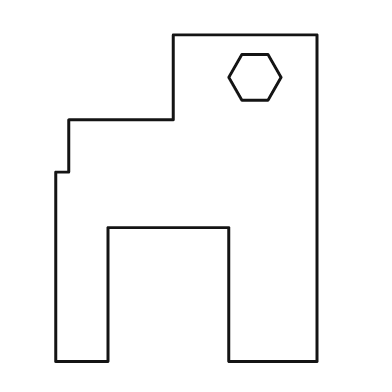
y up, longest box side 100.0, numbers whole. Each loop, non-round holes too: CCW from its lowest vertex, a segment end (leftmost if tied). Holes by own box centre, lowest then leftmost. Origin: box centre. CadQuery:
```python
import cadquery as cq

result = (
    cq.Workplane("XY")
    .moveTo(-40.0, -50.0)
    .lineTo(-24.0, -50.0)
    .lineTo(-24.0, -9.0)
    .lineTo(13.0, -9.0)
    .lineTo(13.0, -50.0)
    .lineTo(40.0, -50.0)
    .lineTo(40.0, 50.0)
    .lineTo(-4.0, 50.0)
    .lineTo(-4.0, 24.0)
    .lineTo(-36.0, 24.0)
    .lineTo(-36.0, 8.0)
    .lineTo(-40.0, 8.0)
    .close()
    .moveTo(17.0, 30.0)
    .lineTo(25.0, 30.0)
    .lineTo(29.0, 37.0)
    .lineTo(25.0, 44.0)
    .lineTo(17.0, 44.0)
    .lineTo(13.0, 37.0)
    .close()
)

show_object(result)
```